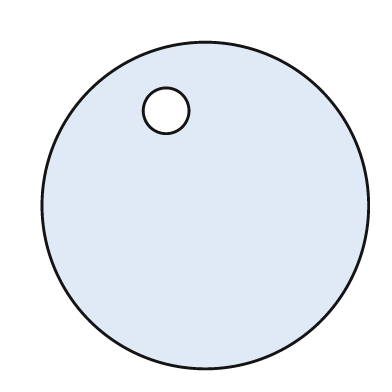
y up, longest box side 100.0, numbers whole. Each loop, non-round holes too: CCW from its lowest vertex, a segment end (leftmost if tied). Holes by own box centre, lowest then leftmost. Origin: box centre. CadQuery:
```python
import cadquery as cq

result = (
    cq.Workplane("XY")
    .moveTo(0.0, 0.0)
    .circle(50.0)
    .moveTo(-12.0, 29.0)
    .circle(7.0)
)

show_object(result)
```